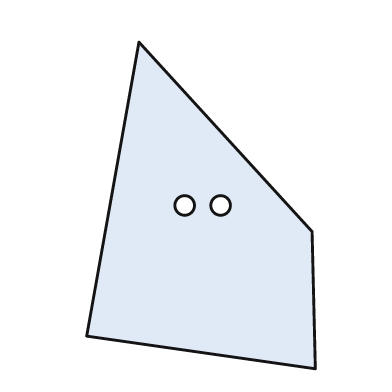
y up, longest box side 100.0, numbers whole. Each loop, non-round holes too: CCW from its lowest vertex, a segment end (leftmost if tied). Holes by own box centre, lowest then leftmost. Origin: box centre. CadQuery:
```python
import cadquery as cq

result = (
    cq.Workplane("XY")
    .moveTo(35.0, -50.0)
    .lineTo(34.0, -8.0)
    .lineTo(-19.0, 50.0)
    .lineTo(-35.0, -40.0)
    .close()
    .moveTo(-5.0, 0.0)
    .circle(3.0)
    .moveTo(6.0, 0.0)
    .circle(3.0)
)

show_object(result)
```